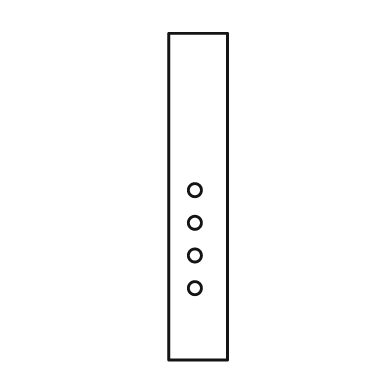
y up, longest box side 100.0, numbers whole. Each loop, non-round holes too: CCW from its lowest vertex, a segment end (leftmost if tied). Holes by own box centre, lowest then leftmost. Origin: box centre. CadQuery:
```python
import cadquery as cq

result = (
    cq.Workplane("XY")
    .moveTo(-9.0, -50.0)
    .lineTo(9.0, -50.0)
    .lineTo(9.0, 50.0)
    .lineTo(-9.0, 50.0)
    .close()
    .moveTo(-1.0, -28.0)
    .circle(2.0)
    .moveTo(-1.0, -18.0)
    .circle(2.0)
    .moveTo(-1.0, -8.0)
    .circle(2.0)
    .moveTo(-1.0, 2.0)
    .circle(2.0)
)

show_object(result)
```